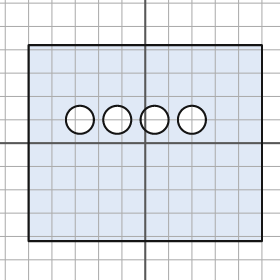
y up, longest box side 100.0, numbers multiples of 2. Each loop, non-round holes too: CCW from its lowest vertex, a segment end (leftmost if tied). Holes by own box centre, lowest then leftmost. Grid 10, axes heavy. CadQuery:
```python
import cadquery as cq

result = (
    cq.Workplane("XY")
    .moveTo(-50.0, -42.0)
    .lineTo(50.0, -42.0)
    .lineTo(50.0, 42.0)
    .lineTo(-50.0, 42.0)
    .close()
    .moveTo(-28.0, 10.0)
    .circle(6.0)
    .moveTo(-12.0, 10.0)
    .circle(6.0)
    .moveTo(4.0, 10.0)
    .circle(6.0)
    .moveTo(20.0, 10.0)
    .circle(6.0)
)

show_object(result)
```